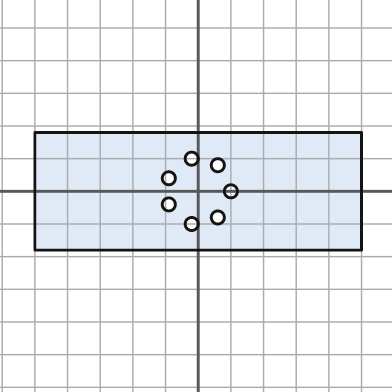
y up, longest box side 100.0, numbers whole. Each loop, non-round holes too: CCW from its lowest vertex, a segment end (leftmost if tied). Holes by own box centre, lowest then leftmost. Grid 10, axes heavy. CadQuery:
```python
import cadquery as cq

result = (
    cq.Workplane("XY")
    .moveTo(-50.0, -18.0)
    .lineTo(50.0, -18.0)
    .lineTo(50.0, 18.0)
    .lineTo(-50.0, 18.0)
    .close()
    .moveTo(-2.0, -10.0)
    .circle(2.0)
    .moveTo(6.0, -8.0)
    .circle(2.0)
    .moveTo(-9.0, -4.0)
    .circle(2.0)
    .moveTo(10.0, 0.0)
    .circle(2.0)
    .moveTo(-9.0, 4.0)
    .circle(2.0)
    .moveTo(6.0, 8.0)
    .circle(2.0)
    .moveTo(-2.0, 10.0)
    .circle(2.0)
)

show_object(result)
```